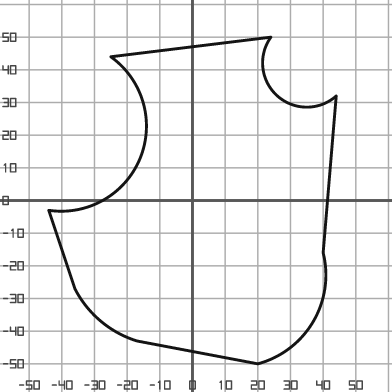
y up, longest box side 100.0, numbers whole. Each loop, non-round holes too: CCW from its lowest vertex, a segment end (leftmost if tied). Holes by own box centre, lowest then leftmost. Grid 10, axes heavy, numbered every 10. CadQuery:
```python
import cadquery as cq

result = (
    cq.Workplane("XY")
    .moveTo(20.0, -50.0)
    .threePointArc((37.0, -37.0), (40.0, -16.0))
    .lineTo(44.0, 32.0)
    .threePointArc((26.0, 32.0), (24.0, 50.0))
    .lineTo(-25.0, 44.0)
    .threePointArc((-16.0, 13.0), (-44.0, -3.0))
    .lineTo(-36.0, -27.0)
    .threePointArc((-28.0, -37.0), (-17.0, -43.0))
    .close()
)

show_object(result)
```